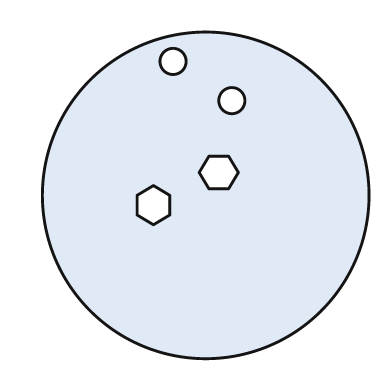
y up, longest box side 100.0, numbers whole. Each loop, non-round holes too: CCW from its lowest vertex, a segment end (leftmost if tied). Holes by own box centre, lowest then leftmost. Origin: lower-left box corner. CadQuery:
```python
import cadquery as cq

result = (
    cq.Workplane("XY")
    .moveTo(50.0, 50.0)
    .circle(50.0)
    .moveTo(34.0, 41.0)
    .lineTo(39.0, 44.0)
    .lineTo(39.0, 50.0)
    .lineTo(34.0, 53.0)
    .lineTo(29.0, 50.0)
    .lineTo(29.0, 44.0)
    .close()
    .moveTo(51.0, 52.0)
    .lineTo(57.0, 52.0)
    .lineTo(60.0, 57.0)
    .lineTo(57.0, 62.0)
    .lineTo(51.0, 62.0)
    .lineTo(48.0, 57.0)
    .close()
    .moveTo(58.0, 79.0)
    .circle(4.0)
    .moveTo(40.0, 91.0)
    .circle(4.0)
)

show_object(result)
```